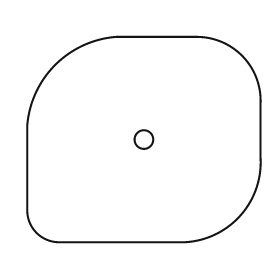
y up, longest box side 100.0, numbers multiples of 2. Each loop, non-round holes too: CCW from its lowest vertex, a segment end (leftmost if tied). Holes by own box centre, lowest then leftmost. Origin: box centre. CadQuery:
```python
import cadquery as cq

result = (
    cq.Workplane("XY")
    .moveTo(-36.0, -44.0)
    .lineTo(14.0, -44.0)
    .threePointArc((40.0, -34.0), (50.0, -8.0))
    .lineTo(50.0, 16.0)
    .threePointArc((42.0, 36.0), (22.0, 44.0))
    .lineTo(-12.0, 44.0)
    .threePointArc((-38.0, 32.0), (-50.0, 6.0))
    .lineTo(-50.0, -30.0)
    .threePointArc((-46.0, -40.0), (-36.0, -44.0))
    .close()
    .moveTo(0.0, 0.0)
    .circle(4.0)
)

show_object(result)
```